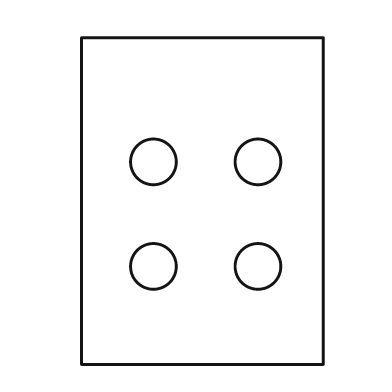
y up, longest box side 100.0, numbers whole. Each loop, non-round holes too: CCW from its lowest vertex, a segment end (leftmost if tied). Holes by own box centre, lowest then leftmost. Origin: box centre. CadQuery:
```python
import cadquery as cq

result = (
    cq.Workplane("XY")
    .moveTo(-37.0, -50.0)
    .lineTo(37.0, -50.0)
    .lineTo(37.0, 50.0)
    .lineTo(-37.0, 50.0)
    .close()
    .moveTo(-15.0, -20.0)
    .circle(7.0)
    .moveTo(17.0, -20.0)
    .circle(7.0)
    .moveTo(-15.0, 12.0)
    .circle(7.0)
    .moveTo(17.0, 12.0)
    .circle(7.0)
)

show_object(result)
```